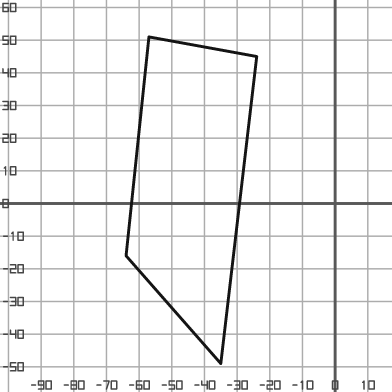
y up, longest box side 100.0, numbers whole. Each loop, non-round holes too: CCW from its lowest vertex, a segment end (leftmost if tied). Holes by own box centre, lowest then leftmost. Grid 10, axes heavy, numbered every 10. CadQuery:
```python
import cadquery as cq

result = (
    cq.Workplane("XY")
    .moveTo(-35.0, -49.0)
    .lineTo(-24.0, 45.0)
    .lineTo(-57.0, 51.0)
    .lineTo(-64.0, -16.0)
    .close()
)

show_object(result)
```